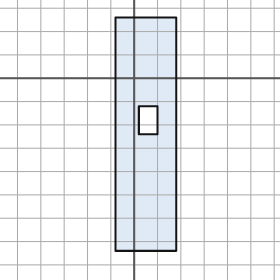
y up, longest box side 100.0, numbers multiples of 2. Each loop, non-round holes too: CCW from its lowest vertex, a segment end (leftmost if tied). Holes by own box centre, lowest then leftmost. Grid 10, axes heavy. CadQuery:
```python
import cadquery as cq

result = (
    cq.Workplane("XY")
    .moveTo(-8.0, -74.0)
    .lineTo(18.0, -74.0)
    .lineTo(18.0, 26.0)
    .lineTo(-8.0, 26.0)
    .close()
    .moveTo(2.0, -24.0)
    .lineTo(10.0, -24.0)
    .lineTo(10.0, -12.0)
    .lineTo(2.0, -12.0)
    .close()
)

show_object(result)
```